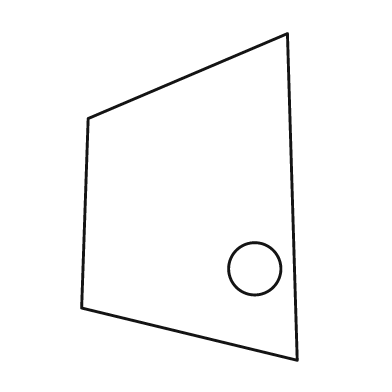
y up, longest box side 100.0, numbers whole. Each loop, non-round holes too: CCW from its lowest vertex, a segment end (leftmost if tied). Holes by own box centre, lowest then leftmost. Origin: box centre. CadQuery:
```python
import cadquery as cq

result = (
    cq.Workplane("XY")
    .moveTo(33.0, -50.0)
    .lineTo(30.0, 50.0)
    .lineTo(-31.0, 24.0)
    .lineTo(-33.0, -34.0)
    .close()
    .moveTo(20.0, -22.0)
    .circle(8.0)
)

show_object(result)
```